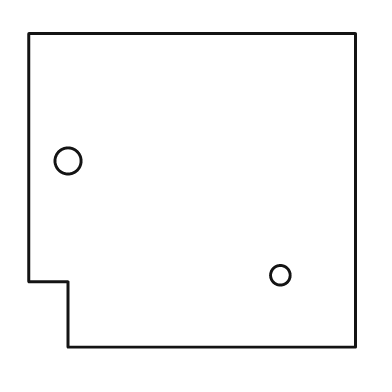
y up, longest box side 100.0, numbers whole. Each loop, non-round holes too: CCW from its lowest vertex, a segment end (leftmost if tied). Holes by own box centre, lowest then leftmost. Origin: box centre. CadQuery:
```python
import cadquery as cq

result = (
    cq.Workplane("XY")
    .moveTo(-38.0, -48.0)
    .lineTo(50.0, -48.0)
    .lineTo(50.0, 48.0)
    .lineTo(-50.0, 48.0)
    .lineTo(-50.0, -28.0)
    .lineTo(-38.0, -28.0)
    .close()
    .moveTo(27.0, -26.0)
    .circle(3.0)
    .moveTo(-38.0, 9.0)
    .circle(4.0)
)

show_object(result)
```